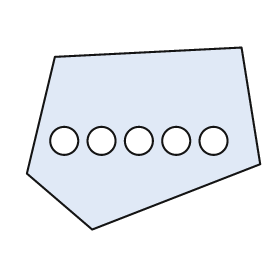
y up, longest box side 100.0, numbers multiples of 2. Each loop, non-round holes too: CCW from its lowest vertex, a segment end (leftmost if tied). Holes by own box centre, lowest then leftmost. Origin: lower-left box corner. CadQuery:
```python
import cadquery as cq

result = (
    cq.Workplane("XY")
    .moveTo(28.0, 0.0)
    .lineTo(100.0, 28.0)
    .lineTo(92.0, 78.0)
    .lineTo(12.0, 74.0)
    .lineTo(0.0, 24.0)
    .close()
    .moveTo(16.0, 38.0)
    .circle(6.0)
    .moveTo(32.0, 38.0)
    .circle(6.0)
    .moveTo(48.0, 38.0)
    .circle(6.0)
    .moveTo(64.0, 38.0)
    .circle(6.0)
    .moveTo(80.0, 38.0)
    .circle(6.0)
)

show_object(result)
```